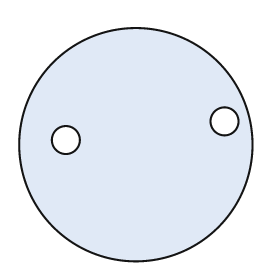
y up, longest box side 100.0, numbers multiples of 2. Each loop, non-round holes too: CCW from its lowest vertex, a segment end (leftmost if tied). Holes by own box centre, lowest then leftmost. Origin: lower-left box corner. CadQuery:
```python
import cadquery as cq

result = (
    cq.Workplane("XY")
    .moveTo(50.0, 50.0)
    .circle(50.0)
    .moveTo(20.0, 52.0)
    .circle(6.0)
    .moveTo(88.0, 60.0)
    .circle(6.0)
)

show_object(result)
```